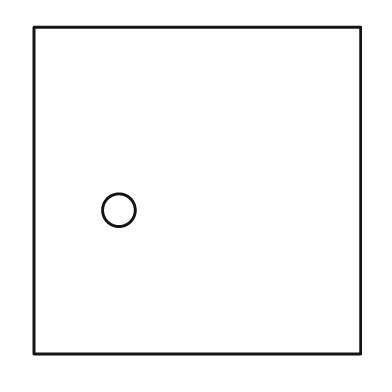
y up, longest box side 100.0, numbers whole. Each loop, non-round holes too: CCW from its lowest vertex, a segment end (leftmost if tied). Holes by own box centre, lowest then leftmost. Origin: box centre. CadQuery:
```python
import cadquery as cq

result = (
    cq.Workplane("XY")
    .moveTo(-50.0, -50.0)
    .lineTo(50.0, -50.0)
    .lineTo(50.0, 50.0)
    .lineTo(-50.0, 50.0)
    .close()
    .moveTo(-24.0, -6.0)
    .circle(5.0)
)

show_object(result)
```